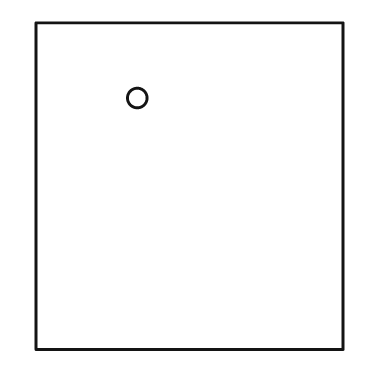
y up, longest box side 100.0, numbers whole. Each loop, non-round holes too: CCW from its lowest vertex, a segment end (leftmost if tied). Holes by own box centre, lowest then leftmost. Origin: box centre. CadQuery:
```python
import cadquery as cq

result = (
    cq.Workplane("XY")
    .moveTo(-47.0, -50.0)
    .lineTo(47.0, -50.0)
    .lineTo(47.0, 50.0)
    .lineTo(-47.0, 50.0)
    .close()
    .moveTo(-16.0, 27.0)
    .circle(3.0)
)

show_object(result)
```